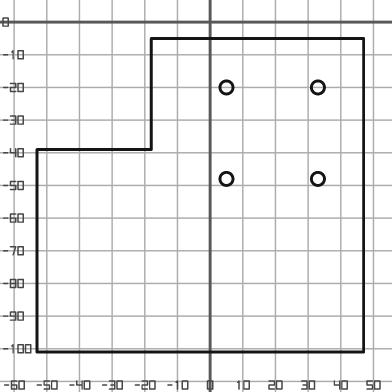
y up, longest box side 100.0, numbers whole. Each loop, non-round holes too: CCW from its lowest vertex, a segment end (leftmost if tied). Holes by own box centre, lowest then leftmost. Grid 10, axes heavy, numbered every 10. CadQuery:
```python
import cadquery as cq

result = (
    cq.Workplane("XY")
    .moveTo(-53.0, -101.0)
    .lineTo(47.0, -101.0)
    .lineTo(47.0, -5.0)
    .lineTo(-18.0, -5.0)
    .lineTo(-18.0, -39.0)
    .lineTo(-53.0, -39.0)
    .close()
    .moveTo(5.0, -48.0)
    .circle(2.0)
    .moveTo(33.0, -48.0)
    .circle(2.0)
    .moveTo(5.0, -20.0)
    .circle(2.0)
    .moveTo(33.0, -20.0)
    .circle(2.0)
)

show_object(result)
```